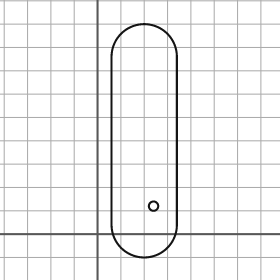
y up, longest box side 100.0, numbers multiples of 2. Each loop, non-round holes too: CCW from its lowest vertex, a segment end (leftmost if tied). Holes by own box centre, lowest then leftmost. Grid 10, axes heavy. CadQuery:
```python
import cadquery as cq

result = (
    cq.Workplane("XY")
    .moveTo(6.0, 4.0)
    .threePointArc((20.0, -10.0), (34.0, 4.0))
    .lineTo(34.0, 76.0)
    .threePointArc((20.0, 90.0), (6.0, 76.0))
    .close()
    .moveTo(24.0, 12.0)
    .circle(2.0)
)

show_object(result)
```